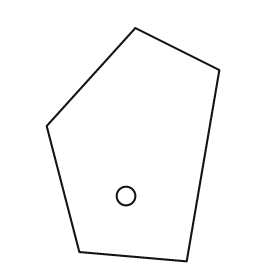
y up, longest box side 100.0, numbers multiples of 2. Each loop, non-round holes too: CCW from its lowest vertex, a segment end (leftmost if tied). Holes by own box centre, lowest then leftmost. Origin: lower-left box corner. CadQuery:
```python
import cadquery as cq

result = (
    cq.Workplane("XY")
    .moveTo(60.0, 0.0)
    .lineTo(74.0, 82.0)
    .lineTo(38.0, 100.0)
    .lineTo(0.0, 58.0)
    .lineTo(14.0, 4.0)
    .close()
    .moveTo(34.0, 28.0)
    .circle(4.0)
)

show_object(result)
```